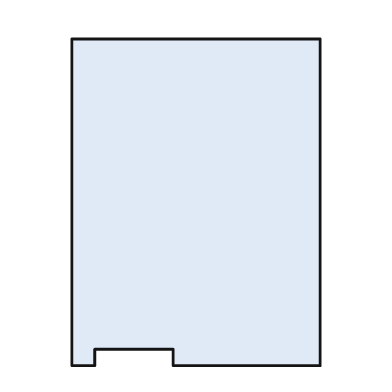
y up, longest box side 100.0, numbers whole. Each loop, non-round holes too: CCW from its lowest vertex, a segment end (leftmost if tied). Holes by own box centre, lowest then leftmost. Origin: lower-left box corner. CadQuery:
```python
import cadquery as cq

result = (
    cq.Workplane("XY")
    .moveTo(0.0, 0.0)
    .lineTo(7.0, 0.0)
    .lineTo(7.0, 5.0)
    .lineTo(31.0, 5.0)
    .lineTo(31.0, 0.0)
    .lineTo(76.0, 0.0)
    .lineTo(76.0, 100.0)
    .lineTo(0.0, 100.0)
    .close()
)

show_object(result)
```